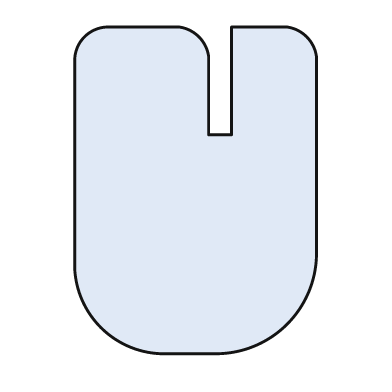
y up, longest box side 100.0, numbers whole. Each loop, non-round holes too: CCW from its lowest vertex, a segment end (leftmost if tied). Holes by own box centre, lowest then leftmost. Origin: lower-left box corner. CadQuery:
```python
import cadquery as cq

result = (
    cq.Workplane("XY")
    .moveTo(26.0, 0.0)
    .lineTo(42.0, 0.0)
    .threePointArc((65.0, 9.0), (74.0, 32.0))
    .lineTo(74.0, 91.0)
    .threePointArc((71.0, 97.0), (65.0, 100.0))
    .lineTo(48.0, 100.0)
    .lineTo(48.0, 67.0)
    .lineTo(41.0, 67.0)
    .lineTo(41.0, 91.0)
    .threePointArc((38.0, 97.0), (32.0, 100.0))
    .lineTo(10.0, 100.0)
    .threePointArc((3.0, 97.0), (0.0, 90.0))
    .lineTo(0.0, 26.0)
    .threePointArc((8.0, 8.0), (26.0, 0.0))
    .close()
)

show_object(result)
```